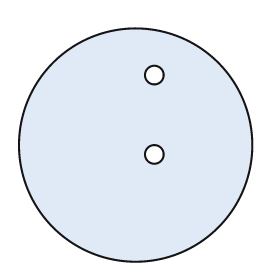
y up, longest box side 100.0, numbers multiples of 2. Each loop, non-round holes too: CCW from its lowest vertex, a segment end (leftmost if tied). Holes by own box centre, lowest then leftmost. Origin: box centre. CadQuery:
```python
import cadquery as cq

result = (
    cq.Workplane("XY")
    .moveTo(0.0, 0.0)
    .circle(50.0)
    .moveTo(8.0, -4.0)
    .circle(4.0)
    .moveTo(8.0, 30.0)
    .circle(4.0)
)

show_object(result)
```